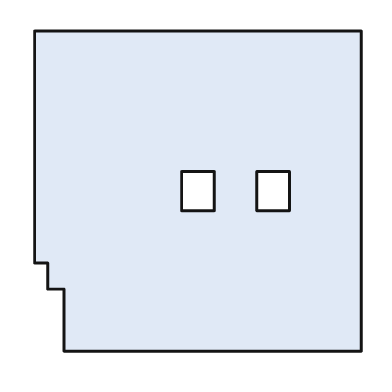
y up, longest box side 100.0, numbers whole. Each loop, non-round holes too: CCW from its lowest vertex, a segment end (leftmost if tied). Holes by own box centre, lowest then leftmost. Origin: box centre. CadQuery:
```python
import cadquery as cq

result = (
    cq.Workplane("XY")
    .moveTo(-41.0, -49.0)
    .lineTo(50.0, -49.0)
    .lineTo(50.0, 49.0)
    .lineTo(-50.0, 49.0)
    .lineTo(-50.0, -22.0)
    .lineTo(-46.0, -22.0)
    .lineTo(-46.0, -30.0)
    .lineTo(-41.0, -30.0)
    .close()
    .moveTo(-5.0, -6.0)
    .lineTo(5.0, -6.0)
    .lineTo(5.0, 6.0)
    .lineTo(-5.0, 6.0)
    .close()
    .moveTo(18.0, -6.0)
    .lineTo(28.0, -6.0)
    .lineTo(28.0, 6.0)
    .lineTo(18.0, 6.0)
    .close()
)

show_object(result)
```